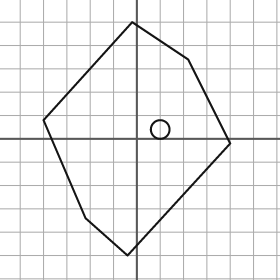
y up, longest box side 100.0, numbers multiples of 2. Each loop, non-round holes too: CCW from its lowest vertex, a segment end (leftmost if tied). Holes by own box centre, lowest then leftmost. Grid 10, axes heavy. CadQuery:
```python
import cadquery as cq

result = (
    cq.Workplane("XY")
    .moveTo(-4.0, -50.0)
    .lineTo(40.0, -2.0)
    .lineTo(22.0, 34.0)
    .lineTo(-2.0, 50.0)
    .lineTo(-40.0, 8.0)
    .lineTo(-22.0, -34.0)
    .close()
    .moveTo(10.0, 4.0)
    .circle(4.0)
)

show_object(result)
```